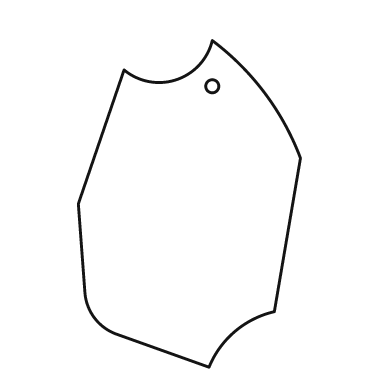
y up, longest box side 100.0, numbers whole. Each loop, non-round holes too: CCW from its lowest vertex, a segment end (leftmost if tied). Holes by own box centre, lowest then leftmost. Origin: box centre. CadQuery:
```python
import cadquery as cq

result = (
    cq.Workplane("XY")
    .moveTo(6.0, -50.0)
    .threePointArc((14.0, -39.0), (26.0, -33.0))
    .lineTo(34.0, 14.0)
    .threePointArc((23.0, 34.0), (7.0, 50.0))
    .threePointArc((-4.0, 38.0), (-20.0, 41.0))
    .lineTo(-34.0, 0.0)
    .lineTo(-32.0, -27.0)
    .threePointArc((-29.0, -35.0), (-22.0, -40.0))
    .close()
    .moveTo(7.0, 36.0)
    .circle(2.0)
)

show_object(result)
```